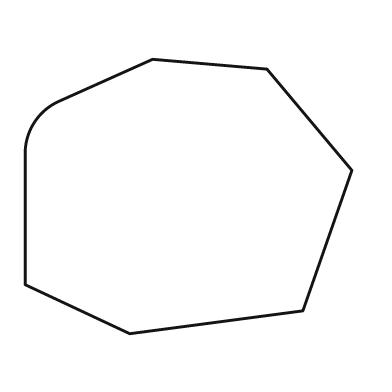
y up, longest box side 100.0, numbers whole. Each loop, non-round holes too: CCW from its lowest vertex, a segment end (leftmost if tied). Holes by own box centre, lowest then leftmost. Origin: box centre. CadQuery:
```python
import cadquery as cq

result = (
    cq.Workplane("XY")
    .moveTo(-18.0, -42.0)
    .lineTo(35.0, -35.0)
    .lineTo(50.0, 8.0)
    .lineTo(24.0, 39.0)
    .lineTo(-11.0, 42.0)
    .lineTo(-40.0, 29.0)
    .threePointArc((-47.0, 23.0), (-50.0, 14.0))
    .lineTo(-50.0, -27.0)
    .close()
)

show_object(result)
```